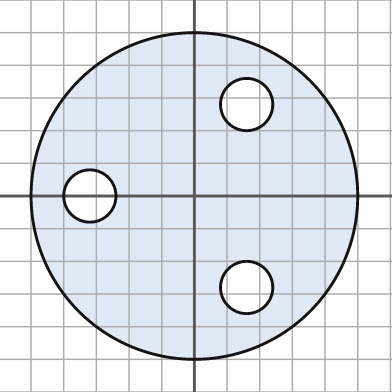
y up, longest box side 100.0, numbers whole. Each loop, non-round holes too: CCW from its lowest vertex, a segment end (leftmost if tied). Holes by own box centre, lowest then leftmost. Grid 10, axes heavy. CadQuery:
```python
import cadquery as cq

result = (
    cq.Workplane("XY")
    .moveTo(0.0, 0.0)
    .circle(50.0)
    .moveTo(16.0, -28.0)
    .circle(8.0)
    .moveTo(-32.0, 0.0)
    .circle(8.0)
    .moveTo(16.0, 28.0)
    .circle(8.0)
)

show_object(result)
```